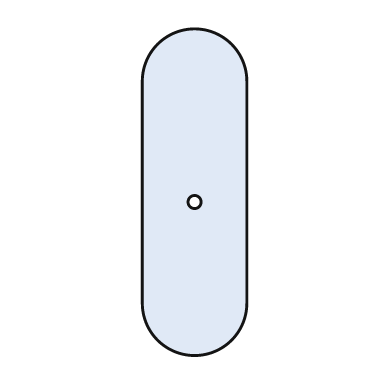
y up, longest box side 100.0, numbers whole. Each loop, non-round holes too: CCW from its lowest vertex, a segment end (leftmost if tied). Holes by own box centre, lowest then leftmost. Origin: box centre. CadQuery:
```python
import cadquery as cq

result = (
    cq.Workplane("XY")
    .moveTo(-16.0, -34.0)
    .threePointArc((0.0, -50.0), (16.0, -34.0))
    .lineTo(16.0, 34.0)
    .threePointArc((0.0, 50.0), (-16.0, 34.0))
    .close()
    .moveTo(0.0, -3.0)
    .circle(2.0)
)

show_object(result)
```